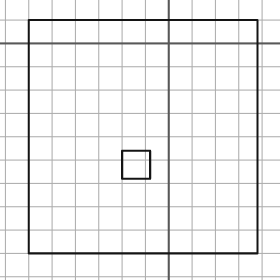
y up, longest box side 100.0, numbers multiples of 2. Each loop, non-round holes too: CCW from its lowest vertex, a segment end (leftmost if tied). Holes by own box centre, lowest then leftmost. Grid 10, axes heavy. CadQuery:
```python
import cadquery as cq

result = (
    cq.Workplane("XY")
    .moveTo(-60.0, -90.0)
    .lineTo(38.0, -90.0)
    .lineTo(38.0, 10.0)
    .lineTo(-60.0, 10.0)
    .close()
    .moveTo(-20.0, -58.0)
    .lineTo(-8.0, -58.0)
    .lineTo(-8.0, -46.0)
    .lineTo(-20.0, -46.0)
    .close()
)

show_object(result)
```